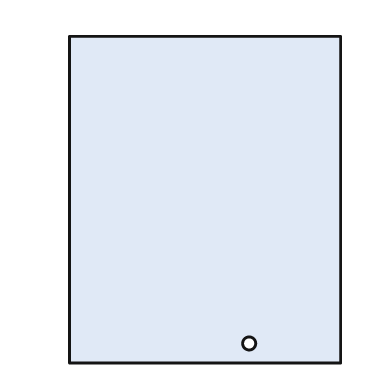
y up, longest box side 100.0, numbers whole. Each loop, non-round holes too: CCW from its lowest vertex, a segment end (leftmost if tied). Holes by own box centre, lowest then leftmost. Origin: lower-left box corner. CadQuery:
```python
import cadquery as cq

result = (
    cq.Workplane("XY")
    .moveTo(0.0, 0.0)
    .lineTo(83.0, 0.0)
    .lineTo(83.0, 100.0)
    .lineTo(0.0, 100.0)
    .close()
    .moveTo(55.0, 6.0)
    .circle(2.0)
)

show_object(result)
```